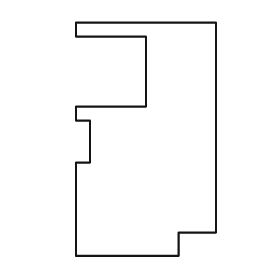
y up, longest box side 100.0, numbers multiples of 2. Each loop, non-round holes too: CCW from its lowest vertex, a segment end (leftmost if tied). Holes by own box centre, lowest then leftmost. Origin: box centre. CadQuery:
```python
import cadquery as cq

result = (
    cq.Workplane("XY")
    .moveTo(-30.0, -50.0)
    .lineTo(14.0, -50.0)
    .lineTo(14.0, -40.0)
    .lineTo(30.0, -40.0)
    .lineTo(30.0, 50.0)
    .lineTo(-30.0, 50.0)
    .lineTo(-30.0, 44.0)
    .lineTo(0.0, 44.0)
    .lineTo(0.0, 14.0)
    .lineTo(-30.0, 14.0)
    .lineTo(-30.0, 8.0)
    .lineTo(-24.0, 8.0)
    .lineTo(-24.0, -10.0)
    .lineTo(-30.0, -10.0)
    .close()
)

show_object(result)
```